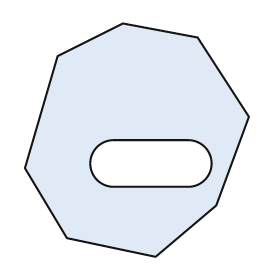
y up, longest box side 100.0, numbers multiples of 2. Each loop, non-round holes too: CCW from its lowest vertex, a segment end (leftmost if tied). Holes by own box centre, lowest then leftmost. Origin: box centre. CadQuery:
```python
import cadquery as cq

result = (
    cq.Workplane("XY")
    .moveTo(8.0, -50.0)
    .lineTo(34.0, -28.0)
    .lineTo(48.0, 10.0)
    .lineTo(26.0, 44.0)
    .lineTo(-6.0, 50.0)
    .lineTo(-34.0, 36.0)
    .lineTo(-48.0, -12.0)
    .lineTo(-30.0, -42.0)
    .close()
    .moveTo(-10.0, -20.0)
    .lineTo(22.0, -20.0)
    .threePointArc((32.0, -10.0), (22.0, 0.0))
    .lineTo(-10.0, 0.0)
    .threePointArc((-20.0, -10.0), (-10.0, -20.0))
    .close()
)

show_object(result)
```